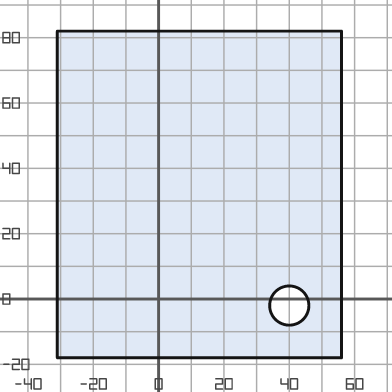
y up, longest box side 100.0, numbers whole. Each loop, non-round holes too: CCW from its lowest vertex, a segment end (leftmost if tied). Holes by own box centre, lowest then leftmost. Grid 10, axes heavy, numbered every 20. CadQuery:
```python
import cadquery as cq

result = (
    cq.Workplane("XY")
    .moveTo(-31.0, -18.0)
    .lineTo(56.0, -18.0)
    .lineTo(56.0, 82.0)
    .lineTo(-31.0, 82.0)
    .close()
    .moveTo(40.0, -2.0)
    .circle(6.0)
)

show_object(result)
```